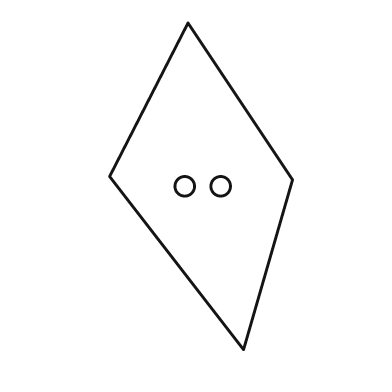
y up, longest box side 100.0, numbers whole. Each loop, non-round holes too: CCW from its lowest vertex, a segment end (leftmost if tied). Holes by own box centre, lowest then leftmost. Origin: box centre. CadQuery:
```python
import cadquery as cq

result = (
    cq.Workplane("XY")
    .moveTo(13.0, -50.0)
    .lineTo(28.0, 2.0)
    .lineTo(-4.0, 50.0)
    .lineTo(-28.0, 3.0)
    .close()
    .moveTo(-5.0, 0.0)
    .circle(3.0)
    .moveTo(6.0, 0.0)
    .circle(3.0)
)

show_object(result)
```